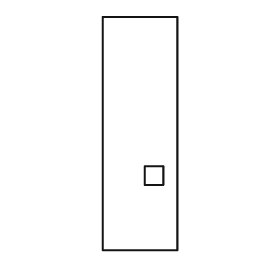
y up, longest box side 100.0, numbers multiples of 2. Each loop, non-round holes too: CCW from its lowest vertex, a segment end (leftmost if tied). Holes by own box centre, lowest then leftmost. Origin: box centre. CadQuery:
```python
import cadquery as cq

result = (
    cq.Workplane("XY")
    .moveTo(-16.0, -50.0)
    .lineTo(16.0, -50.0)
    .lineTo(16.0, 50.0)
    .lineTo(-16.0, 50.0)
    .close()
    .moveTo(2.0, -22.0)
    .lineTo(10.0, -22.0)
    .lineTo(10.0, -14.0)
    .lineTo(2.0, -14.0)
    .close()
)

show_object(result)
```